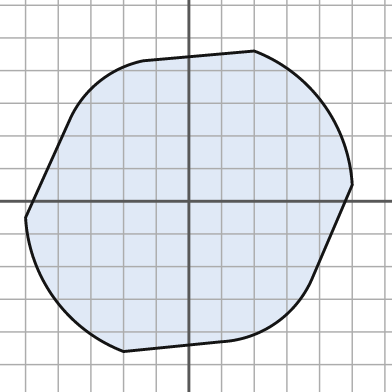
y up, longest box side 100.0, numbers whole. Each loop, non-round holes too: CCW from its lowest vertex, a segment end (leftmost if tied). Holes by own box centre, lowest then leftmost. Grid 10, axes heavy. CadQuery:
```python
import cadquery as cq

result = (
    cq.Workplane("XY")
    .moveTo(-20.0, -46.0)
    .lineTo(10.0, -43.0)
    .threePointArc((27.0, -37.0), (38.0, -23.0))
    .lineTo(50.0, 5.0)
    .threePointArc((41.0, 30.0), (20.0, 46.0))
    .lineTo(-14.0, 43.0)
    .threePointArc((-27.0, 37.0), (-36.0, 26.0))
    .lineTo(-50.0, -5.0)
    .threePointArc((-41.0, -30.0), (-20.0, -46.0))
    .close()
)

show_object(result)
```